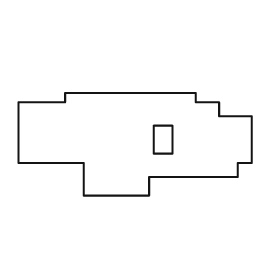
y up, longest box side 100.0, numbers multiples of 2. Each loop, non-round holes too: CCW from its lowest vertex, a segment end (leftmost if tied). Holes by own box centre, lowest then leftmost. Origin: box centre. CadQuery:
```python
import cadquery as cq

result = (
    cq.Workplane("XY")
    .moveTo(-22.0, -22.0)
    .lineTo(6.0, -22.0)
    .lineTo(6.0, -14.0)
    .lineTo(44.0, -14.0)
    .lineTo(44.0, -8.0)
    .lineTo(50.0, -8.0)
    .lineTo(50.0, 12.0)
    .lineTo(36.0, 12.0)
    .lineTo(36.0, 18.0)
    .lineTo(26.0, 18.0)
    .lineTo(26.0, 22.0)
    .lineTo(-30.0, 22.0)
    .lineTo(-30.0, 18.0)
    .lineTo(-50.0, 18.0)
    .lineTo(-50.0, -8.0)
    .lineTo(-22.0, -8.0)
    .close()
    .moveTo(8.0, -4.0)
    .lineTo(16.0, -4.0)
    .lineTo(16.0, 8.0)
    .lineTo(8.0, 8.0)
    .close()
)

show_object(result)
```